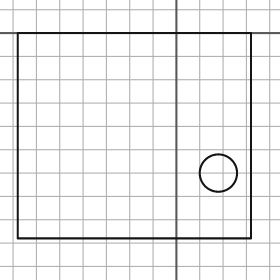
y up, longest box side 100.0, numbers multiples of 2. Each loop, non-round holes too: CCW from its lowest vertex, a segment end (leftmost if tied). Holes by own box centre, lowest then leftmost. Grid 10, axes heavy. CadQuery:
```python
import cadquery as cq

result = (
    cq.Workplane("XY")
    .moveTo(-68.0, -88.0)
    .lineTo(32.0, -88.0)
    .lineTo(32.0, 0.0)
    .lineTo(-68.0, 0.0)
    .close()
    .moveTo(18.0, -60.0)
    .circle(8.0)
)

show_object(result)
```